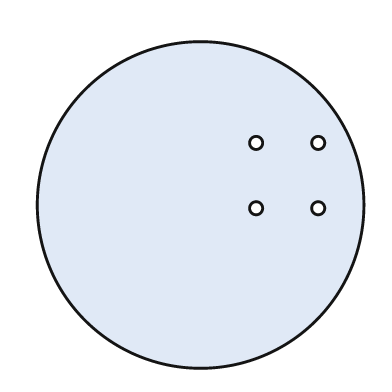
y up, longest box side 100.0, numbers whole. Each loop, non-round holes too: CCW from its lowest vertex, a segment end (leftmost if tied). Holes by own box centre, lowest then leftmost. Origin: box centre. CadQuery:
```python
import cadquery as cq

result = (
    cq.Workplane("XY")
    .moveTo(0.0, 0.0)
    .circle(50.0)
    .moveTo(17.0, -1.0)
    .circle(2.0)
    .moveTo(36.0, -1.0)
    .circle(2.0)
    .moveTo(17.0, 19.0)
    .circle(2.0)
    .moveTo(36.0, 19.0)
    .circle(2.0)
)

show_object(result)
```